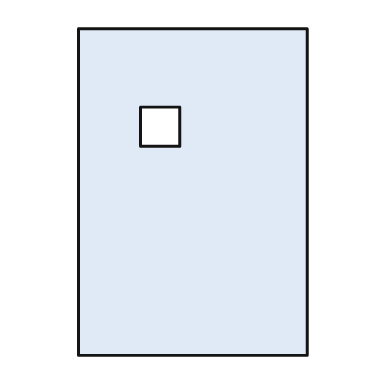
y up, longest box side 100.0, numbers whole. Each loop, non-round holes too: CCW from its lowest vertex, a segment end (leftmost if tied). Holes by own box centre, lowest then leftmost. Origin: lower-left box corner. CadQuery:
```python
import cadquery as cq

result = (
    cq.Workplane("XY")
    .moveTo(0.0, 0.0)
    .lineTo(70.0, 0.0)
    .lineTo(70.0, 100.0)
    .lineTo(0.0, 100.0)
    .close()
    .moveTo(19.0, 64.0)
    .lineTo(31.0, 64.0)
    .lineTo(31.0, 76.0)
    .lineTo(19.0, 76.0)
    .close()
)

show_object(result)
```